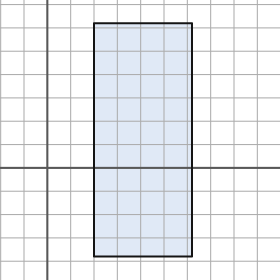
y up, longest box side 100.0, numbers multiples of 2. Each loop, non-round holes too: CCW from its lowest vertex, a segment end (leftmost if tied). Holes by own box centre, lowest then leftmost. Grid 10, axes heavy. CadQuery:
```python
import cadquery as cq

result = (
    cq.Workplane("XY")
    .moveTo(20.0, -38.0)
    .lineTo(62.0, -38.0)
    .lineTo(62.0, 62.0)
    .lineTo(20.0, 62.0)
    .close()
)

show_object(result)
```